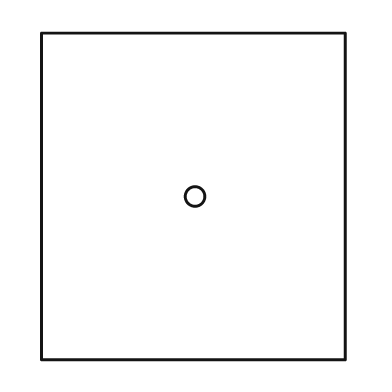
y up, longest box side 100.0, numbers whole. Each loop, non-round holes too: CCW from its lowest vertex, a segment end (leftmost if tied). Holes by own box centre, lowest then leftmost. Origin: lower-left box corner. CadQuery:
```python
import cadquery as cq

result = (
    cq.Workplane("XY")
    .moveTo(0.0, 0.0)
    .lineTo(93.0, 0.0)
    .lineTo(93.0, 100.0)
    .lineTo(0.0, 100.0)
    .close()
    .moveTo(47.0, 50.0)
    .circle(3.0)
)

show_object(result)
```